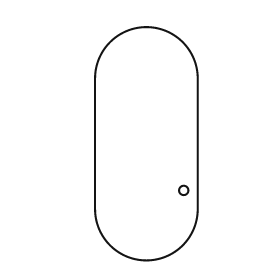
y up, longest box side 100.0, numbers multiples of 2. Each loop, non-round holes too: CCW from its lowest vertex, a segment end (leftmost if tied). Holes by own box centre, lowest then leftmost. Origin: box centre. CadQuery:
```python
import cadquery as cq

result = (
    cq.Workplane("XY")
    .moveTo(-22.0, -28.0)
    .threePointArc((0.0, -50.0), (22.0, -28.0))
    .lineTo(22.0, 28.0)
    .threePointArc((0.0, 50.0), (-22.0, 28.0))
    .close()
    .moveTo(16.0, -20.0)
    .circle(2.0)
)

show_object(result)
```